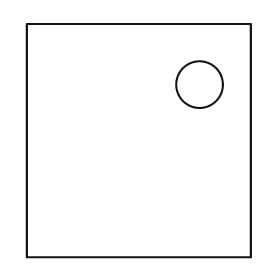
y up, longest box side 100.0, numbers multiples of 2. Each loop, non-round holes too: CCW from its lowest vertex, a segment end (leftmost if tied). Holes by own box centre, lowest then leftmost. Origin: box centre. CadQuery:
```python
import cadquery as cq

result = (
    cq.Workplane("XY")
    .moveTo(-48.0, -50.0)
    .lineTo(48.0, -50.0)
    .lineTo(48.0, 50.0)
    .lineTo(-48.0, 50.0)
    .close()
    .moveTo(26.0, 24.0)
    .circle(10.0)
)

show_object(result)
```